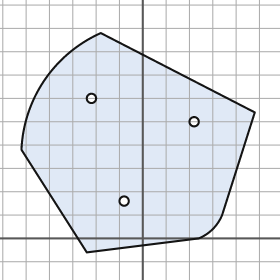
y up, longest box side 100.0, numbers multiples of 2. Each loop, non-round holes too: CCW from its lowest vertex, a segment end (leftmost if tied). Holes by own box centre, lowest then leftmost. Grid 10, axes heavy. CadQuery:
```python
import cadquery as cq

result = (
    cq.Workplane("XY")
    .moveTo(-24.0, -6.0)
    .lineTo(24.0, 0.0)
    .threePointArc((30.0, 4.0), (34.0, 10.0))
    .lineTo(48.0, 54.0)
    .lineTo(-18.0, 88.0)
    .threePointArc((-42.0, 68.0), (-52.0, 38.0))
    .close()
    .moveTo(-8.0, 16.0)
    .circle(2.0)
    .moveTo(22.0, 50.0)
    .circle(2.0)
    .moveTo(-22.0, 60.0)
    .circle(2.0)
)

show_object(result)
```